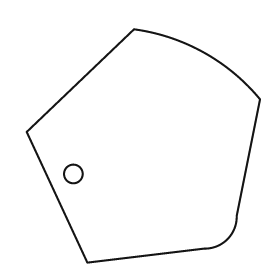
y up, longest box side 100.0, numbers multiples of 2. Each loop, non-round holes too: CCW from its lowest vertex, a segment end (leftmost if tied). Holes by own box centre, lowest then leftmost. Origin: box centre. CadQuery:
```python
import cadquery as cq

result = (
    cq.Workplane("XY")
    .moveTo(-24.0, -50.0)
    .lineTo(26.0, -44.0)
    .threePointArc((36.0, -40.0), (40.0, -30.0))
    .lineTo(50.0, 20.0)
    .threePointArc((26.0, 40.0), (-4.0, 50.0))
    .lineTo(-50.0, 6.0)
    .close()
    .moveTo(-30.0, -12.0)
    .circle(4.0)
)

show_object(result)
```